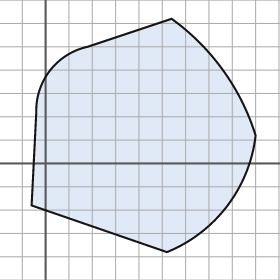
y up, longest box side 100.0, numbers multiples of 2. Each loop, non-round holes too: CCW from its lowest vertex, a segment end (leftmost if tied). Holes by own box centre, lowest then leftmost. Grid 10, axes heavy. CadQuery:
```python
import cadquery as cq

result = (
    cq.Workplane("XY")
    .moveTo(52.0, -38.0)
    .threePointArc((78.0, -18.0), (90.0, 12.0))
    .threePointArc((76.0, 40.0), (54.0, 62.0))
    .lineTo(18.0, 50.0)
    .threePointArc((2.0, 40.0), (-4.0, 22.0))
    .lineTo(-6.0, -18.0)
    .close()
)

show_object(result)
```